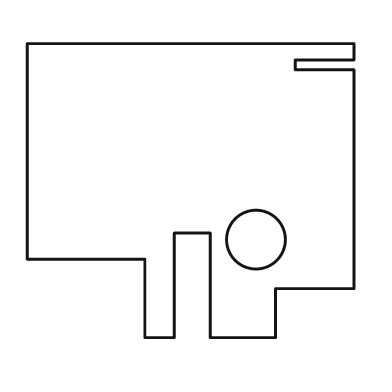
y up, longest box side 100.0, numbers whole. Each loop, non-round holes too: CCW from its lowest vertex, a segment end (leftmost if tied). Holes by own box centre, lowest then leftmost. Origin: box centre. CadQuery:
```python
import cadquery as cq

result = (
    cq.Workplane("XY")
    .moveTo(-14.0, -45.0)
    .lineTo(-5.0, -45.0)
    .lineTo(-5.0, -13.0)
    .lineTo(6.0, -13.0)
    .lineTo(6.0, -45.0)
    .lineTo(26.0, -45.0)
    .lineTo(26.0, -30.0)
    .lineTo(50.0, -30.0)
    .lineTo(50.0, 37.0)
    .lineTo(32.0, 37.0)
    .lineTo(32.0, 40.0)
    .lineTo(50.0, 40.0)
    .lineTo(50.0, 45.0)
    .lineTo(-50.0, 45.0)
    .lineTo(-50.0, -21.0)
    .lineTo(-14.0, -21.0)
    .close()
    .moveTo(20.0, -15.0)
    .circle(9.0)
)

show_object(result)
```